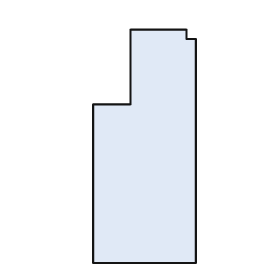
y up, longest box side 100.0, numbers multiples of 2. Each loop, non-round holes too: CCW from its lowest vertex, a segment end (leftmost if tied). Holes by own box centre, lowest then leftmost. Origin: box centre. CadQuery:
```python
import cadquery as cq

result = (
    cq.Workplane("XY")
    .moveTo(-22.0, -50.0)
    .lineTo(22.0, -50.0)
    .lineTo(22.0, 46.0)
    .lineTo(18.0, 46.0)
    .lineTo(18.0, 50.0)
    .lineTo(-6.0, 50.0)
    .lineTo(-6.0, 18.0)
    .lineTo(-22.0, 18.0)
    .close()
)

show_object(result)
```